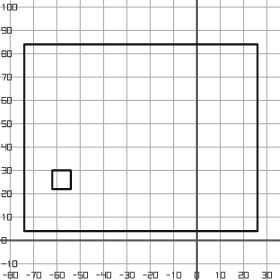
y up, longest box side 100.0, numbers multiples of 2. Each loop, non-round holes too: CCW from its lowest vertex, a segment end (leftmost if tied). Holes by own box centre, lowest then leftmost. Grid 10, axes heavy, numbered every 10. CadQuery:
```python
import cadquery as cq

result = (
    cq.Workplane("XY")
    .moveTo(-74.0, 4.0)
    .lineTo(26.0, 4.0)
    .lineTo(26.0, 84.0)
    .lineTo(-74.0, 84.0)
    .close()
    .moveTo(-62.0, 22.0)
    .lineTo(-54.0, 22.0)
    .lineTo(-54.0, 30.0)
    .lineTo(-62.0, 30.0)
    .close()
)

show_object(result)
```